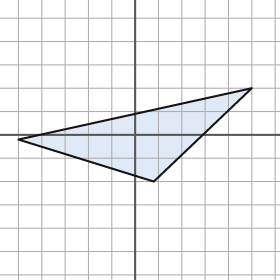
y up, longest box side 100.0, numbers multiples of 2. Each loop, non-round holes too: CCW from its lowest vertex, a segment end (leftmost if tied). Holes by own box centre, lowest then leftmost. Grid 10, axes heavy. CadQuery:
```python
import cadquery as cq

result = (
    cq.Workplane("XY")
    .moveTo(8.0, -20.0)
    .lineTo(50.0, 20.0)
    .lineTo(-50.0, -2.0)
    .close()
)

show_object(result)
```